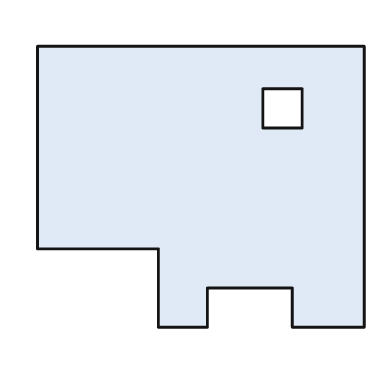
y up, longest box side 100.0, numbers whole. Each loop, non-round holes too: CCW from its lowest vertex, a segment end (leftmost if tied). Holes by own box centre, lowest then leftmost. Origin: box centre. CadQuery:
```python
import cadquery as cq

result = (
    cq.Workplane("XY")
    .moveTo(-13.0, -43.0)
    .lineTo(2.0, -43.0)
    .lineTo(2.0, -31.0)
    .lineTo(28.0, -31.0)
    .lineTo(28.0, -43.0)
    .lineTo(50.0, -43.0)
    .lineTo(50.0, 43.0)
    .lineTo(-50.0, 43.0)
    .lineTo(-50.0, -19.0)
    .lineTo(-13.0, -19.0)
    .close()
    .moveTo(19.0, 18.0)
    .lineTo(31.0, 18.0)
    .lineTo(31.0, 30.0)
    .lineTo(19.0, 30.0)
    .close()
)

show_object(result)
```